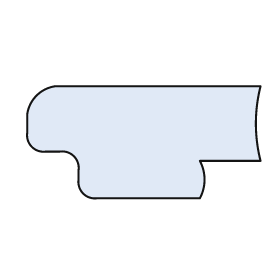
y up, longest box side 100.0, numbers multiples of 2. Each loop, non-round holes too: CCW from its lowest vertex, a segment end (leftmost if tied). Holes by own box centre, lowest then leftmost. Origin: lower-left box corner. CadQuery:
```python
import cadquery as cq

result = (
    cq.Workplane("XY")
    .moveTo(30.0, 0.0)
    .lineTo(74.0, 0.0)
    .threePointArc((76.0, 8.0), (74.0, 16.0))
    .lineTo(100.0, 16.0)
    .threePointArc((98.0, 32.0), (100.0, 48.0))
    .lineTo(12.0, 48.0)
    .threePointArc((4.0, 44.0), (0.0, 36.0))
    .lineTo(0.0, 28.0)
    .threePointArc((2.0, 22.0), (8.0, 20.0))
    .lineTo(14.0, 20.0)
    .threePointArc((20.0, 18.0), (22.0, 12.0))
    .lineTo(22.0, 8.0)
    .threePointArc((24.0, 2.0), (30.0, 0.0))
    .close()
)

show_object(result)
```